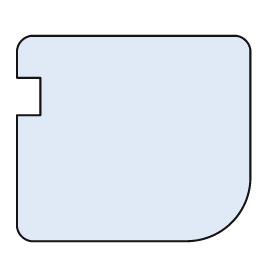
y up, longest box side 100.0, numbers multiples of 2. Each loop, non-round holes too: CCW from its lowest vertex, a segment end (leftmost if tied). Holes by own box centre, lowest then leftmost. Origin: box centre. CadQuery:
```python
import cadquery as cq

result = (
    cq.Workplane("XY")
    .moveTo(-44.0, -44.0)
    .lineTo(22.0, -44.0)
    .threePointArc((42.0, -36.0), (50.0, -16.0))
    .lineTo(50.0, 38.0)
    .threePointArc((48.0, 42.0), (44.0, 44.0))
    .lineTo(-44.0, 44.0)
    .threePointArc((-48.0, 42.0), (-50.0, 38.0))
    .lineTo(-50.0, 26.0)
    .lineTo(-40.0, 26.0)
    .lineTo(-40.0, 10.0)
    .lineTo(-50.0, 10.0)
    .lineTo(-50.0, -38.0)
    .threePointArc((-48.0, -42.0), (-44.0, -44.0))
    .close()
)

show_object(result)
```